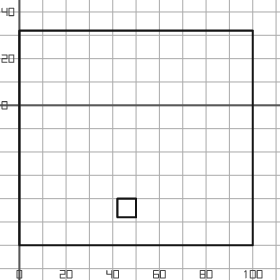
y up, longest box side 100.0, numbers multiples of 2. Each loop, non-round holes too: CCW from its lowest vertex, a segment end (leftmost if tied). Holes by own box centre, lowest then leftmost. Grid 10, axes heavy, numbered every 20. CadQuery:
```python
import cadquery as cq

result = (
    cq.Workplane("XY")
    .moveTo(0.0, -60.0)
    .lineTo(100.0, -60.0)
    .lineTo(100.0, 32.0)
    .lineTo(0.0, 32.0)
    .close()
    .moveTo(42.0, -48.0)
    .lineTo(50.0, -48.0)
    .lineTo(50.0, -40.0)
    .lineTo(42.0, -40.0)
    .close()
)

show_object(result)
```